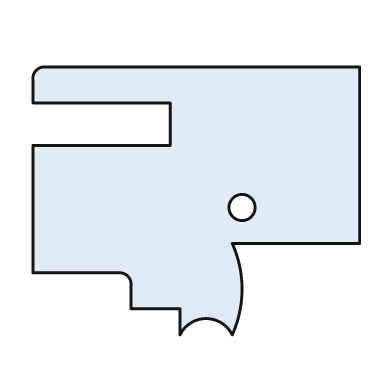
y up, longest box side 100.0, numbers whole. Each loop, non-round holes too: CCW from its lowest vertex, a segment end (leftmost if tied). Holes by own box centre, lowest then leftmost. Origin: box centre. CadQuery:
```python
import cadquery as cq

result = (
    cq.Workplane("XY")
    .moveTo(-5.0, -41.0)
    .threePointArc((3.0, -36.0), (11.0, -41.0))
    .threePointArc((14.0, -27.0), (11.0, -13.0))
    .lineTo(50.0, -13.0)
    .lineTo(50.0, 41.0)
    .lineTo(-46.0, 41.0)
    .threePointArc((-49.0, 40.0), (-50.0, 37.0))
    .lineTo(-50.0, 30.0)
    .lineTo(-8.0, 30.0)
    .lineTo(-8.0, 17.0)
    .lineTo(-50.0, 17.0)
    .lineTo(-50.0, -22.0)
    .lineTo(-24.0, -22.0)
    .threePointArc((-21.0, -23.0), (-20.0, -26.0))
    .lineTo(-20.0, -33.0)
    .lineTo(-5.0, -33.0)
    .close()
    .moveTo(14.0, -2.0)
    .circle(4.0)
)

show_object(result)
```